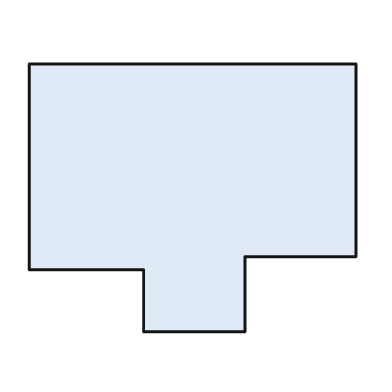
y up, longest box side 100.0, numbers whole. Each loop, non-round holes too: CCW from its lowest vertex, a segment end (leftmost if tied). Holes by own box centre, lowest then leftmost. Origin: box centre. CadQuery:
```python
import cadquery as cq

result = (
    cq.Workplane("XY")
    .moveTo(-15.0, -41.0)
    .lineTo(16.0, -41.0)
    .lineTo(16.0, -18.0)
    .lineTo(50.0, -18.0)
    .lineTo(50.0, 41.0)
    .lineTo(-50.0, 41.0)
    .lineTo(-50.0, -22.0)
    .lineTo(-15.0, -22.0)
    .close()
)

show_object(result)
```